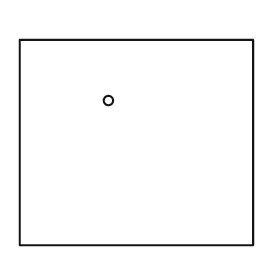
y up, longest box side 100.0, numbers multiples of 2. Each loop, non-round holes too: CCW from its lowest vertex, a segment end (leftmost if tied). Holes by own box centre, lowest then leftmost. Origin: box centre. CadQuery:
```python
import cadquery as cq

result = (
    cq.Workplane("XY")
    .moveTo(-50.0, -44.0)
    .lineTo(50.0, -44.0)
    .lineTo(50.0, 44.0)
    .lineTo(-50.0, 44.0)
    .close()
    .moveTo(-12.0, 18.0)
    .circle(2.0)
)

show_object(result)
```